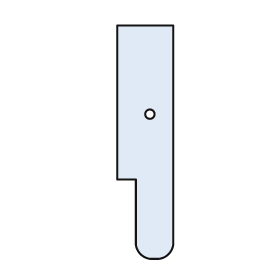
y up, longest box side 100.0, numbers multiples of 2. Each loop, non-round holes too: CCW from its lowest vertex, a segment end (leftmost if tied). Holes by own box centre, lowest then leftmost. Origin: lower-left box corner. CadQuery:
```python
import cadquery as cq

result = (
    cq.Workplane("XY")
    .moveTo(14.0, 0.0)
    .lineTo(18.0, 0.0)
    .threePointArc((22.0, 2.0), (24.0, 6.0))
    .lineTo(24.0, 100.0)
    .lineTo(0.0, 100.0)
    .lineTo(0.0, 34.0)
    .lineTo(8.0, 34.0)
    .lineTo(8.0, 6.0)
    .threePointArc((10.0, 2.0), (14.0, 0.0))
    .close()
    .moveTo(14.0, 62.0)
    .circle(2.0)
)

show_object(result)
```